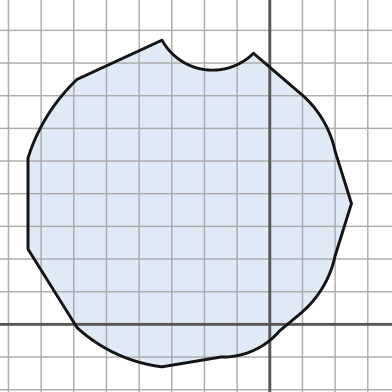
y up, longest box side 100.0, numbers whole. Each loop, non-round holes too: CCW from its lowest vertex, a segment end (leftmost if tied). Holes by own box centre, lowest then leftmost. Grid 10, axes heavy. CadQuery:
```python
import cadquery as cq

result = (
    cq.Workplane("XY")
    .moveTo(-33.0, -13.0)
    .lineTo(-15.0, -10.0)
    .threePointArc((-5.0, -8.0), (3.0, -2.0))
    .lineTo(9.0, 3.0)
    .threePointArc((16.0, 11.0), (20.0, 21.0))
    .lineTo(25.0, 37.0)
    .lineTo(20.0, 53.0)
    .threePointArc((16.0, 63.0), (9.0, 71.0))
    .lineTo(-5.0, 83.0)
    .threePointArc((-20.0, 78.0), (-33.0, 87.0))
    .lineTo(-59.0, 75.0)
    .threePointArc((-68.0, 64.0), (-74.0, 51.0))
    .lineTo(-74.0, 23.0)
    .lineTo(-59.0, -1.0)
    .threePointArc((-47.0, -9.0), (-33.0, -13.0))
    .close()
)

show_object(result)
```